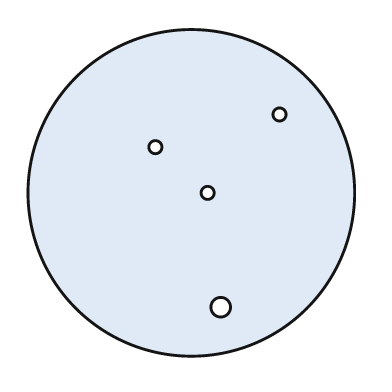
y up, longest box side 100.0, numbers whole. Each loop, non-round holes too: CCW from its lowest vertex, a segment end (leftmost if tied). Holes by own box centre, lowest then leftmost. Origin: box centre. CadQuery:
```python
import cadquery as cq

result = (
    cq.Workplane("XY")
    .moveTo(0.0, 0.0)
    .circle(50.0)
    .moveTo(9.0, -35.0)
    .circle(3.0)
    .moveTo(5.0, 0.0)
    .circle(2.0)
    .moveTo(-11.0, 14.0)
    .circle(2.0)
    .moveTo(27.0, 24.0)
    .circle(2.0)
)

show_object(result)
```